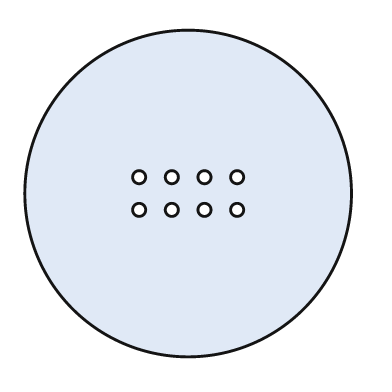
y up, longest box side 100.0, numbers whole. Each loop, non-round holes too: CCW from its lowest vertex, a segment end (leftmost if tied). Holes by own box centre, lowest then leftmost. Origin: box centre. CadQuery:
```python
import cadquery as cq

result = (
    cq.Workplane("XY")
    .moveTo(0.0, 0.0)
    .circle(50.0)
    .moveTo(-15.0, -5.0)
    .circle(2.0)
    .moveTo(-5.0, -5.0)
    .circle(2.0)
    .moveTo(5.0, -5.0)
    .circle(2.0)
    .moveTo(15.0, -5.0)
    .circle(2.0)
    .moveTo(-15.0, 5.0)
    .circle(2.0)
    .moveTo(-5.0, 5.0)
    .circle(2.0)
    .moveTo(5.0, 5.0)
    .circle(2.0)
    .moveTo(15.0, 5.0)
    .circle(2.0)
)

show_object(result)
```